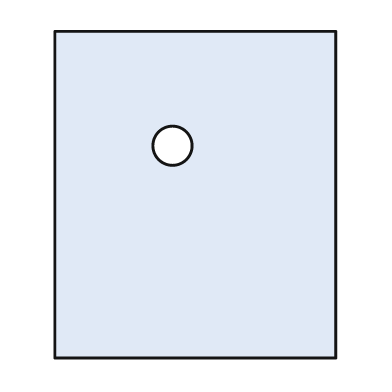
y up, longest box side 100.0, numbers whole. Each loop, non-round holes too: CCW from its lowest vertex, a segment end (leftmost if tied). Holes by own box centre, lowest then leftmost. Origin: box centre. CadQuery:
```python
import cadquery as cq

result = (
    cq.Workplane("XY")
    .moveTo(-43.0, -50.0)
    .lineTo(43.0, -50.0)
    .lineTo(43.0, 50.0)
    .lineTo(-43.0, 50.0)
    .close()
    .moveTo(-7.0, 15.0)
    .circle(6.0)
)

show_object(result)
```